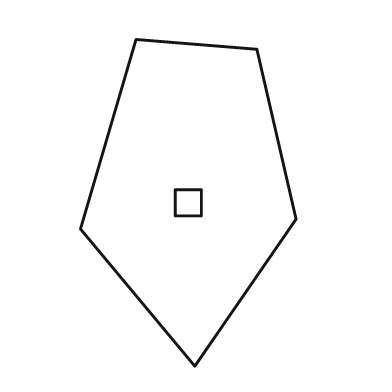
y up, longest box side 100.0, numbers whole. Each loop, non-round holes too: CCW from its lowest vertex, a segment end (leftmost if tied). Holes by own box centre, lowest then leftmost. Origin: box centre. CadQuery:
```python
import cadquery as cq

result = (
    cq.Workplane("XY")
    .moveTo(2.0, -50.0)
    .lineTo(33.0, -5.0)
    .lineTo(21.0, 47.0)
    .lineTo(-16.0, 50.0)
    .lineTo(-33.0, -8.0)
    .close()
    .moveTo(-4.0, -4.0)
    .lineTo(4.0, -4.0)
    .lineTo(4.0, 4.0)
    .lineTo(-4.0, 4.0)
    .close()
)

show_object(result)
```